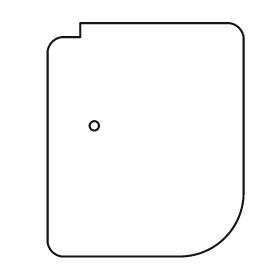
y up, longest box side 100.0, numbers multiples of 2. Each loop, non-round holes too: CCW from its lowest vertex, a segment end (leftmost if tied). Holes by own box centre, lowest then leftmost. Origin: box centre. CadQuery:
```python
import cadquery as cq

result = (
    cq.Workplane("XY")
    .moveTo(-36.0, -50.0)
    .lineTo(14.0, -50.0)
    .threePointArc((34.0, -42.0), (42.0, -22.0))
    .lineTo(42.0, 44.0)
    .threePointArc((40.0, 48.0), (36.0, 50.0))
    .lineTo(-28.0, 50.0)
    .lineTo(-28.0, 44.0)
    .lineTo(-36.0, 44.0)
    .threePointArc((-40.0, 42.0), (-42.0, 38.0))
    .lineTo(-42.0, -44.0)
    .threePointArc((-40.0, -48.0), (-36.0, -50.0))
    .close()
    .moveTo(-22.0, 6.0)
    .circle(2.0)
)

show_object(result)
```